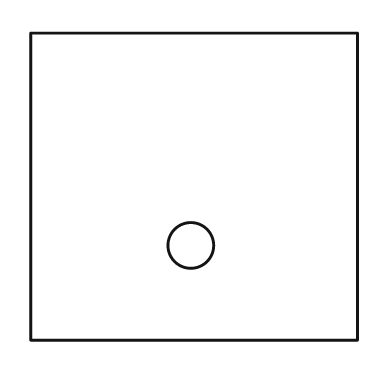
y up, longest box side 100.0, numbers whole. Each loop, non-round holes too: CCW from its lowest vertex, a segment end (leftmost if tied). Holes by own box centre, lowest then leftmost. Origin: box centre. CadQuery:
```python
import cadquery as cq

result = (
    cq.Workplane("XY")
    .moveTo(-50.0, -47.0)
    .lineTo(50.0, -47.0)
    .lineTo(50.0, 47.0)
    .lineTo(-50.0, 47.0)
    .close()
    .moveTo(-1.0, -18.0)
    .circle(7.0)
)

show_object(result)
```